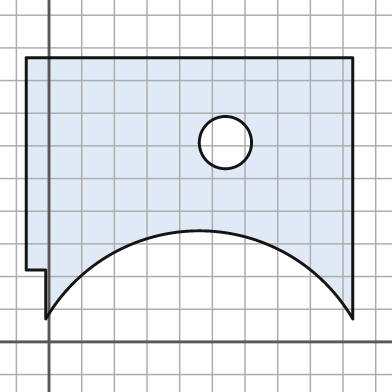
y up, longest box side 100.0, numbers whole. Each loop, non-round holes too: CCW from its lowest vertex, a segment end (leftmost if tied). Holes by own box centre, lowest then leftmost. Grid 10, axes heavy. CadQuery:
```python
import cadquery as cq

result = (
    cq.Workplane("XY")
    .moveTo(-1.0, 7.0)
    .threePointArc((46.0, 34.0), (93.0, 7.0))
    .lineTo(93.0, 87.0)
    .lineTo(-7.0, 87.0)
    .lineTo(-7.0, 22.0)
    .lineTo(-1.0, 22.0)
    .close()
    .moveTo(54.0, 61.0)
    .circle(8.0)
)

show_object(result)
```